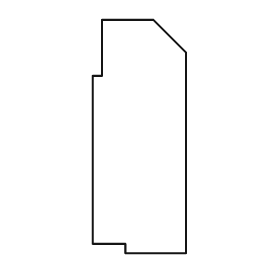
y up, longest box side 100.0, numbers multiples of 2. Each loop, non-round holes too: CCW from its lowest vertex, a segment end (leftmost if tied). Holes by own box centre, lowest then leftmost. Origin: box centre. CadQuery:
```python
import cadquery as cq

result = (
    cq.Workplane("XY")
    .moveTo(-6.0, -50.0)
    .lineTo(20.0, -50.0)
    .lineTo(20.0, 36.0)
    .lineTo(6.0, 50.0)
    .lineTo(-16.0, 50.0)
    .lineTo(-16.0, 26.0)
    .lineTo(-20.0, 26.0)
    .lineTo(-20.0, -46.0)
    .lineTo(-6.0, -46.0)
    .close()
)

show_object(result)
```